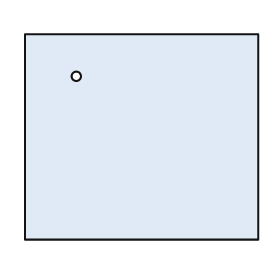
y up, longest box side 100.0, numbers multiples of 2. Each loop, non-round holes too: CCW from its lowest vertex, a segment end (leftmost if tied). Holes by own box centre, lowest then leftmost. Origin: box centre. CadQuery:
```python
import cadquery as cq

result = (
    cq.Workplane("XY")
    .moveTo(-50.0, -44.0)
    .lineTo(50.0, -44.0)
    .lineTo(50.0, 44.0)
    .lineTo(-50.0, 44.0)
    .close()
    .moveTo(-28.0, 26.0)
    .circle(2.0)
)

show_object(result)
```